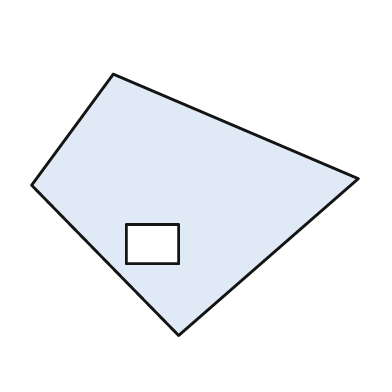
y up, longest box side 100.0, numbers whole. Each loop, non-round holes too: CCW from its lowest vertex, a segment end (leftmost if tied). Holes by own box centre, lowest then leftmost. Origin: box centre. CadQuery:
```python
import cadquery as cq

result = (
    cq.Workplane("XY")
    .moveTo(-5.0, -40.0)
    .lineTo(50.0, 8.0)
    .lineTo(-25.0, 40.0)
    .lineTo(-50.0, 6.0)
    .close()
    .moveTo(-21.0, -18.0)
    .lineTo(-5.0, -18.0)
    .lineTo(-5.0, -6.0)
    .lineTo(-21.0, -6.0)
    .close()
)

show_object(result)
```